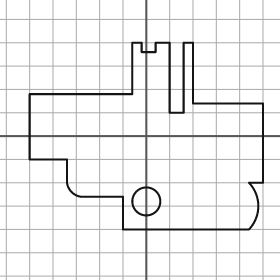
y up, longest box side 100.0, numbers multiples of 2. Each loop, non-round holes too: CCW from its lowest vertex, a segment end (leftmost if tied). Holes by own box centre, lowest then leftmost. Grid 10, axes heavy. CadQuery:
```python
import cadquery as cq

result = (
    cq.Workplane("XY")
    .moveTo(-10.0, -40.0)
    .lineTo(44.0, -40.0)
    .threePointArc((48.0, -30.0), (44.0, -20.0))
    .lineTo(50.0, -20.0)
    .lineTo(50.0, 14.0)
    .lineTo(20.0, 14.0)
    .lineTo(20.0, 40.0)
    .lineTo(16.0, 40.0)
    .lineTo(16.0, 10.0)
    .lineTo(10.0, 10.0)
    .lineTo(10.0, 40.0)
    .lineTo(4.0, 40.0)
    .lineTo(4.0, 36.0)
    .lineTo(-2.0, 36.0)
    .lineTo(-2.0, 40.0)
    .lineTo(-6.0, 40.0)
    .lineTo(-6.0, 18.0)
    .lineTo(-50.0, 18.0)
    .lineTo(-50.0, -10.0)
    .lineTo(-34.0, -10.0)
    .lineTo(-34.0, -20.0)
    .threePointArc((-32.0, -24.0), (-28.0, -26.0))
    .lineTo(-10.0, -26.0)
    .close()
    .moveTo(0.0, -28.0)
    .circle(6.0)
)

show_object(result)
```